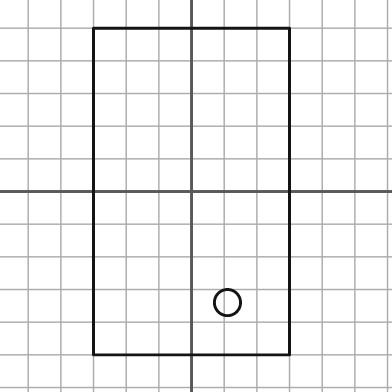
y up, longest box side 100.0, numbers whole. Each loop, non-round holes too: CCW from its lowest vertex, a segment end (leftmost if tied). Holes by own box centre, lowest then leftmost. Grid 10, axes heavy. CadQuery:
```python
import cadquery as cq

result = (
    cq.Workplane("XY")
    .moveTo(-30.0, -50.0)
    .lineTo(30.0, -50.0)
    .lineTo(30.0, 50.0)
    .lineTo(-30.0, 50.0)
    .close()
    .moveTo(11.0, -34.0)
    .circle(4.0)
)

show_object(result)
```